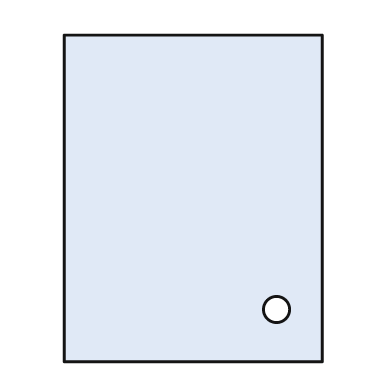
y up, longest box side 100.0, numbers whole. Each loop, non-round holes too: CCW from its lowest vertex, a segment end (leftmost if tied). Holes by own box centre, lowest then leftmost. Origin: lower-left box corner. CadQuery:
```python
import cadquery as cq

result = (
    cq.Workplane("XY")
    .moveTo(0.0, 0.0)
    .lineTo(79.0, 0.0)
    .lineTo(79.0, 100.0)
    .lineTo(0.0, 100.0)
    .close()
    .moveTo(65.0, 16.0)
    .circle(4.0)
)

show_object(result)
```